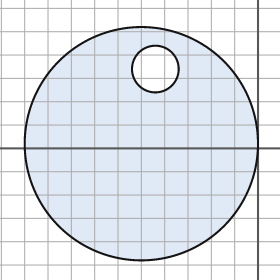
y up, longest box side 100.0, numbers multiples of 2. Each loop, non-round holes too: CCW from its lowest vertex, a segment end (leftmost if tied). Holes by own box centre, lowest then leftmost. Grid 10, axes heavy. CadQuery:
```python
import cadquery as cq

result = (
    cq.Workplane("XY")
    .moveTo(-50.0, 2.0)
    .circle(50.0)
    .moveTo(-44.0, 34.0)
    .circle(10.0)
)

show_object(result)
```